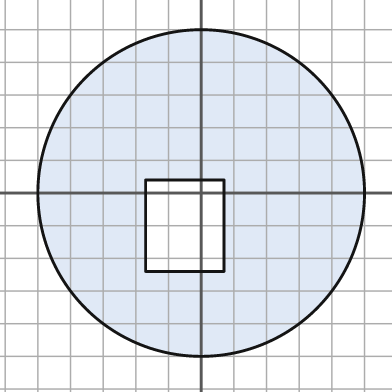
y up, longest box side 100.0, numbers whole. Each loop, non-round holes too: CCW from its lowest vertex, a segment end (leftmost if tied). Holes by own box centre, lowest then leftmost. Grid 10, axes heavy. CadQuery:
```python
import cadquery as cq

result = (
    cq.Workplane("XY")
    .moveTo(0.0, 0.0)
    .circle(50.0)
    .moveTo(-17.0, -24.0)
    .lineTo(7.0, -24.0)
    .lineTo(7.0, 4.0)
    .lineTo(-17.0, 4.0)
    .close()
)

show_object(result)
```